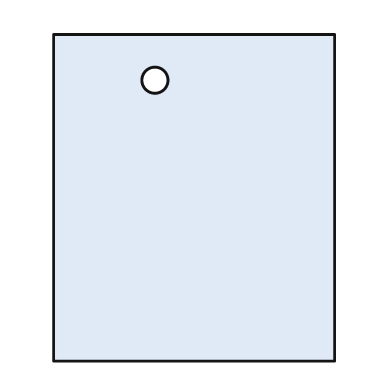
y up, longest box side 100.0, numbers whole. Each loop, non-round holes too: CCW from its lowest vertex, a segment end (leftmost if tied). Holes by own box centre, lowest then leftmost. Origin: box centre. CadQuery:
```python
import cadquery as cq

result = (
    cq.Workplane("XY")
    .moveTo(-43.0, -50.0)
    .lineTo(43.0, -50.0)
    .lineTo(43.0, 50.0)
    .lineTo(-43.0, 50.0)
    .close()
    .moveTo(-12.0, 36.0)
    .circle(4.0)
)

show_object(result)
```